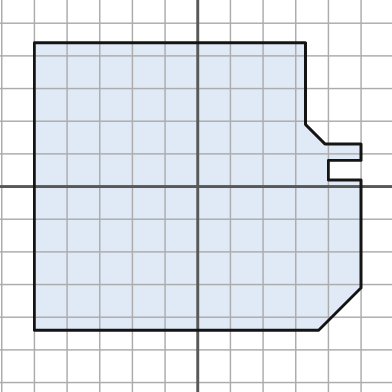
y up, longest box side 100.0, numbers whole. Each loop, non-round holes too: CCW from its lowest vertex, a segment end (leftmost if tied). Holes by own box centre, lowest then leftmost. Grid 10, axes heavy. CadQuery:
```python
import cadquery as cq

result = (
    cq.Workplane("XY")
    .moveTo(-50.0, -44.0)
    .lineTo(37.0, -44.0)
    .lineTo(50.0, -31.0)
    .lineTo(50.0, 2.0)
    .lineTo(40.0, 2.0)
    .lineTo(40.0, 8.0)
    .lineTo(50.0, 8.0)
    .lineTo(50.0, 13.0)
    .lineTo(39.0, 13.0)
    .lineTo(33.0, 19.0)
    .lineTo(33.0, 44.0)
    .lineTo(-50.0, 44.0)
    .close()
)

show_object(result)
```